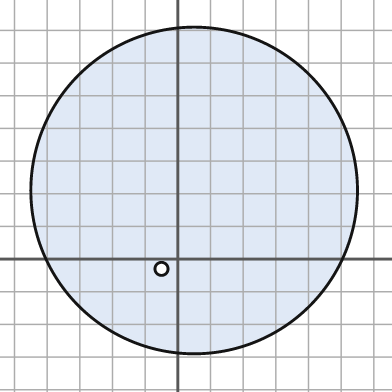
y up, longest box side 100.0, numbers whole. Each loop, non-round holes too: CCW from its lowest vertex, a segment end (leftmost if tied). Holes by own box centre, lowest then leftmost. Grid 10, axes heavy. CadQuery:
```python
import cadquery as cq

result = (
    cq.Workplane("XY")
    .moveTo(5.0, 21.0)
    .circle(50.0)
    .moveTo(-5.0, -3.0)
    .circle(2.0)
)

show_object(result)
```